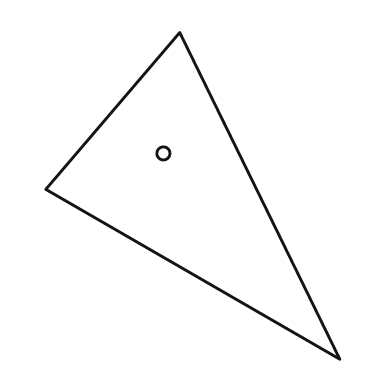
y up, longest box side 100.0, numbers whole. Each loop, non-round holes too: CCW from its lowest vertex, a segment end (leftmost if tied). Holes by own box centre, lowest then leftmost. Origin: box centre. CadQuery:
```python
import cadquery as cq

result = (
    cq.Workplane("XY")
    .moveTo(45.0, -50.0)
    .lineTo(-4.0, 50.0)
    .lineTo(-45.0, 2.0)
    .close()
    .moveTo(-9.0, 13.0)
    .circle(2.0)
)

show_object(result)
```